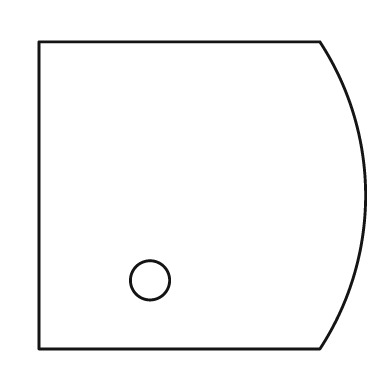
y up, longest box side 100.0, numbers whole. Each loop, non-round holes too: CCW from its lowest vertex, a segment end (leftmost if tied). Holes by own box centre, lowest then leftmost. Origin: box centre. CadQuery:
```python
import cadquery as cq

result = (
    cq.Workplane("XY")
    .moveTo(-50.0, -47.0)
    .lineTo(36.0, -47.0)
    .threePointArc((50.0, 0.0), (36.0, 47.0))
    .lineTo(-50.0, 47.0)
    .close()
    .moveTo(-16.0, -26.0)
    .circle(6.0)
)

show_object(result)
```